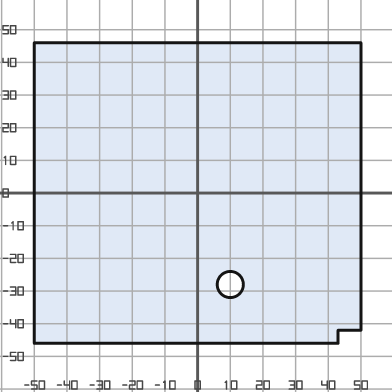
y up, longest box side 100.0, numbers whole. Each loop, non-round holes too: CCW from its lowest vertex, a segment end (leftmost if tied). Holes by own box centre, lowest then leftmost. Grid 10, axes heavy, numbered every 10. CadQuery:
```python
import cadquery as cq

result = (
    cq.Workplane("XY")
    .moveTo(-50.0, -46.0)
    .lineTo(43.0, -46.0)
    .lineTo(43.0, -42.0)
    .lineTo(50.0, -42.0)
    .lineTo(50.0, 46.0)
    .lineTo(-50.0, 46.0)
    .close()
    .moveTo(10.0, -28.0)
    .circle(4.0)
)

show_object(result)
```